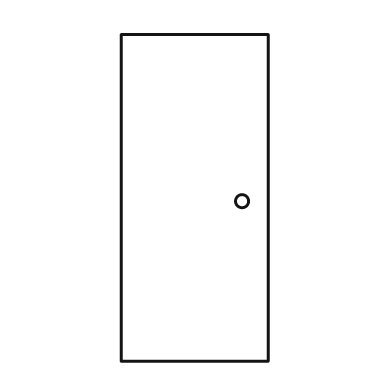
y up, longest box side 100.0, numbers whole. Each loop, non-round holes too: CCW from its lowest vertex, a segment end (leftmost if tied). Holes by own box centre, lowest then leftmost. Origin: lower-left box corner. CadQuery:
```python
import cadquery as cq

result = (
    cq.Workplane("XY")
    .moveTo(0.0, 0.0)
    .lineTo(45.0, 0.0)
    .lineTo(45.0, 100.0)
    .lineTo(0.0, 100.0)
    .close()
    .moveTo(37.0, 49.0)
    .circle(2.0)
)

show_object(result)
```